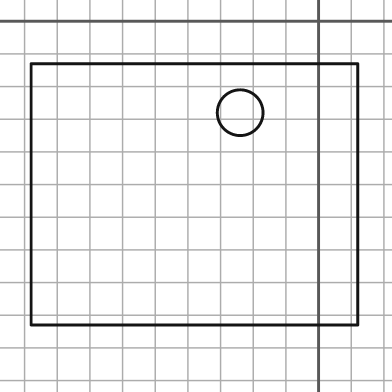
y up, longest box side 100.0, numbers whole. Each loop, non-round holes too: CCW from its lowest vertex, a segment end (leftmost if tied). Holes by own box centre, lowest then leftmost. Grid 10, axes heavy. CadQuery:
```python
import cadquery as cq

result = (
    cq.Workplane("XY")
    .moveTo(-88.0, -93.0)
    .lineTo(12.0, -93.0)
    .lineTo(12.0, -13.0)
    .lineTo(-88.0, -13.0)
    .close()
    .moveTo(-24.0, -28.0)
    .circle(7.0)
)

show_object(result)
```